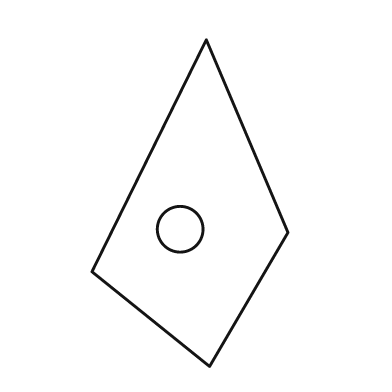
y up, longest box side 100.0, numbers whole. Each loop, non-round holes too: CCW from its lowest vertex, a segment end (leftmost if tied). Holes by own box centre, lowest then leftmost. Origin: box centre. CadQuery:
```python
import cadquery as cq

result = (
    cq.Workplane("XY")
    .moveTo(6.0, -50.0)
    .lineTo(30.0, -9.0)
    .lineTo(5.0, 50.0)
    .lineTo(-30.0, -21.0)
    .close()
    .moveTo(-3.0, -8.0)
    .circle(7.0)
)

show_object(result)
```